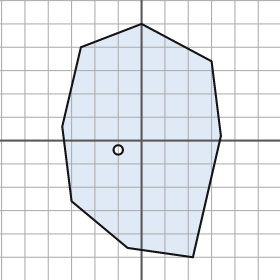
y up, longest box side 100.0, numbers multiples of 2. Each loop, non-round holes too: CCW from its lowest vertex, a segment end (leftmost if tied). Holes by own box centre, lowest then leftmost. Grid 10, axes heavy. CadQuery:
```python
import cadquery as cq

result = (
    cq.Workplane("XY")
    .moveTo(22.0, -50.0)
    .lineTo(34.0, 2.0)
    .lineTo(30.0, 34.0)
    .lineTo(0.0, 50.0)
    .lineTo(-26.0, 40.0)
    .lineTo(-34.0, 6.0)
    .lineTo(-30.0, -26.0)
    .lineTo(-6.0, -46.0)
    .close()
    .moveTo(-10.0, -4.0)
    .circle(2.0)
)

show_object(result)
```